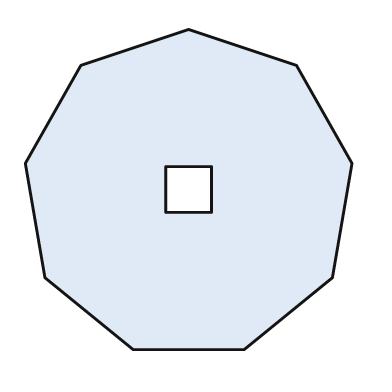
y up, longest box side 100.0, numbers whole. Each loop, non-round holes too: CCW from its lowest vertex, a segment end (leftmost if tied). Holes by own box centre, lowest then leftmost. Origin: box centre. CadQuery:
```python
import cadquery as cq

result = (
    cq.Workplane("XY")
    .moveTo(-17.0, -49.0)
    .lineTo(17.0, -49.0)
    .lineTo(44.0, -27.0)
    .lineTo(50.0, 8.0)
    .lineTo(33.0, 38.0)
    .lineTo(0.0, 49.0)
    .lineTo(-33.0, 38.0)
    .lineTo(-50.0, 8.0)
    .lineTo(-44.0, -27.0)
    .close()
    .moveTo(-7.0, -7.0)
    .lineTo(7.0, -7.0)
    .lineTo(7.0, 7.0)
    .lineTo(-7.0, 7.0)
    .close()
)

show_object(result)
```